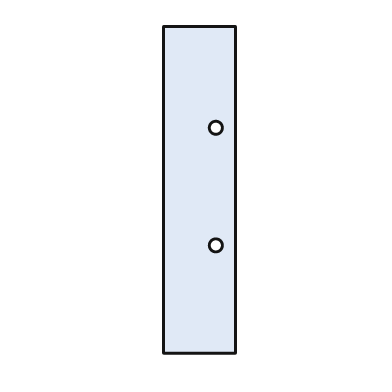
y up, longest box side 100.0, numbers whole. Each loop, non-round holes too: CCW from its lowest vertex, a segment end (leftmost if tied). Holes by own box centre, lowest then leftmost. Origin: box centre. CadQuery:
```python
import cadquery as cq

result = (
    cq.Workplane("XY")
    .moveTo(-11.0, -50.0)
    .lineTo(11.0, -50.0)
    .lineTo(11.0, 50.0)
    .lineTo(-11.0, 50.0)
    .close()
    .moveTo(5.0, -17.0)
    .circle(2.0)
    .moveTo(5.0, 19.0)
    .circle(2.0)
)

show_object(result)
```